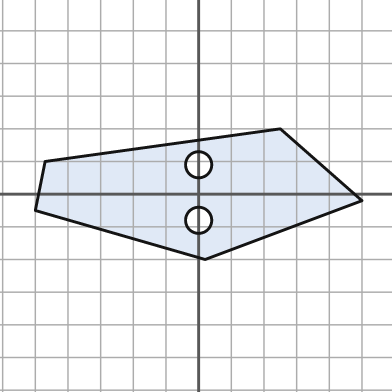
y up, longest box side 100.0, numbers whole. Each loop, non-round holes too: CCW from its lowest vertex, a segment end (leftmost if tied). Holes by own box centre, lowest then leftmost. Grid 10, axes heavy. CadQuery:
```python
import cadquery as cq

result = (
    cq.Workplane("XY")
    .moveTo(2.0, -20.0)
    .lineTo(50.0, -2.0)
    .lineTo(25.0, 20.0)
    .lineTo(-47.0, 10.0)
    .lineTo(-50.0, -5.0)
    .close()
    .moveTo(0.0, -8.0)
    .circle(4.0)
    .moveTo(0.0, 9.0)
    .circle(4.0)
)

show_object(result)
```